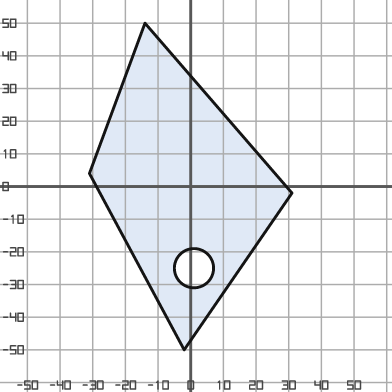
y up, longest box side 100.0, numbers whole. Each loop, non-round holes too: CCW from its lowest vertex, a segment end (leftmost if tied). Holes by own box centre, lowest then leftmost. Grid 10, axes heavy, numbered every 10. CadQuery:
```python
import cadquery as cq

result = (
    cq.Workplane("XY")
    .moveTo(-2.0, -50.0)
    .lineTo(31.0, -2.0)
    .lineTo(-14.0, 50.0)
    .lineTo(-31.0, 4.0)
    .close()
    .moveTo(1.0, -25.0)
    .circle(6.0)
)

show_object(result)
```